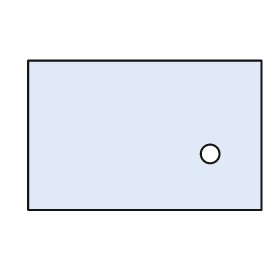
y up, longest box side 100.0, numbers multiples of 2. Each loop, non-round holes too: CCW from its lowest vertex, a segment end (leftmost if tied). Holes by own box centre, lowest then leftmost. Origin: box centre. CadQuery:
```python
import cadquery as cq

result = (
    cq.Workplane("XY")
    .moveTo(-50.0, -32.0)
    .lineTo(50.0, -32.0)
    .lineTo(50.0, 32.0)
    .lineTo(-50.0, 32.0)
    .close()
    .moveTo(28.0, -8.0)
    .circle(4.0)
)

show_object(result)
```